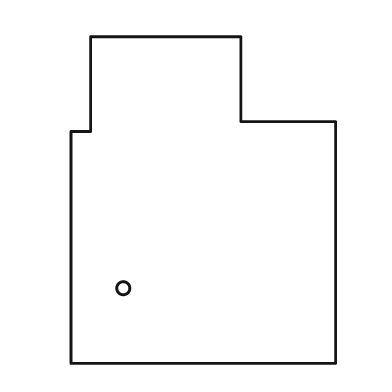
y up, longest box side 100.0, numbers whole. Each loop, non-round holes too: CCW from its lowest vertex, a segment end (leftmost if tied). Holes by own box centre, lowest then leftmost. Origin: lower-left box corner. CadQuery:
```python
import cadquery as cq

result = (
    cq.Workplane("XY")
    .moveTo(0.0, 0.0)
    .lineTo(81.0, 0.0)
    .lineTo(81.0, 74.0)
    .lineTo(52.0, 74.0)
    .lineTo(52.0, 100.0)
    .lineTo(6.0, 100.0)
    .lineTo(6.0, 71.0)
    .lineTo(0.0, 71.0)
    .close()
    .moveTo(16.0, 23.0)
    .circle(2.0)
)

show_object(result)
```